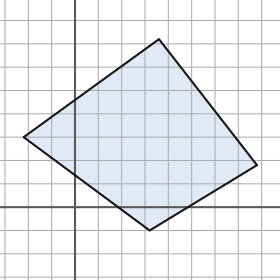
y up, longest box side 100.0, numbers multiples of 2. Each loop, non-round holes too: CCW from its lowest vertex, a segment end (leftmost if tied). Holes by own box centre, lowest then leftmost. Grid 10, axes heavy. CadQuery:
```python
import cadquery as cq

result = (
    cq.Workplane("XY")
    .moveTo(32.0, -10.0)
    .lineTo(78.0, 18.0)
    .lineTo(36.0, 72.0)
    .lineTo(-22.0, 30.0)
    .close()
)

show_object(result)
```